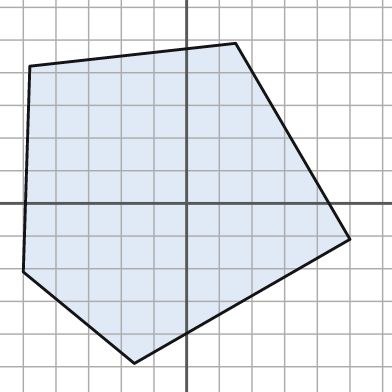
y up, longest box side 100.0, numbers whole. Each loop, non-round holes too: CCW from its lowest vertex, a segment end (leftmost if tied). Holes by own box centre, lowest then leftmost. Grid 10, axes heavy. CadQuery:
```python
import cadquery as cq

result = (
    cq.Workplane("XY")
    .moveTo(-16.0, -49.0)
    .lineTo(50.0, -11.0)
    .lineTo(15.0, 49.0)
    .lineTo(-48.0, 42.0)
    .lineTo(-50.0, -21.0)
    .close()
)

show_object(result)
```